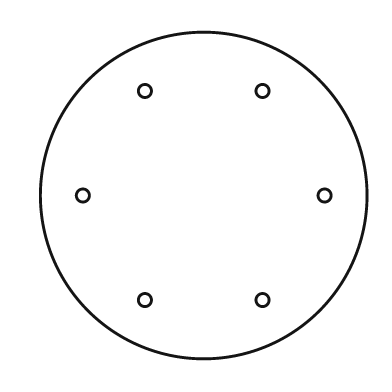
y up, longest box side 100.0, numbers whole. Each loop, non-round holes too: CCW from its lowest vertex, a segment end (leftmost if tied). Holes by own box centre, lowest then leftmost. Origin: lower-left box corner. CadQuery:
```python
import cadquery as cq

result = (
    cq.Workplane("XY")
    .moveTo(50.0, 50.0)
    .circle(50.0)
    .moveTo(32.0, 18.0)
    .circle(2.0)
    .moveTo(68.0, 18.0)
    .circle(2.0)
    .moveTo(13.0, 50.0)
    .circle(2.0)
    .moveTo(87.0, 50.0)
    .circle(2.0)
    .moveTo(32.0, 82.0)
    .circle(2.0)
    .moveTo(68.0, 82.0)
    .circle(2.0)
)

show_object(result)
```